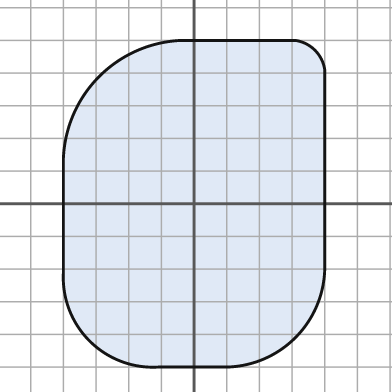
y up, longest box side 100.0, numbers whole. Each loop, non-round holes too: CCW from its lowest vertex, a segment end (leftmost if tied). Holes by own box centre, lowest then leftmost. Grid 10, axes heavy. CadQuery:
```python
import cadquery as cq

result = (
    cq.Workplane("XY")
    .moveTo(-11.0, -50.0)
    .lineTo(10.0, -50.0)
    .threePointArc((31.0, -41.0), (40.0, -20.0))
    .lineTo(40.0, 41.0)
    .threePointArc((37.0, 47.0), (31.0, 50.0))
    .lineTo(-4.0, 50.0)
    .threePointArc((-29.0, 39.0), (-40.0, 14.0))
    .lineTo(-40.0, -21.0)
    .threePointArc((-32.0, -42.0), (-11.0, -50.0))
    .close()
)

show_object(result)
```